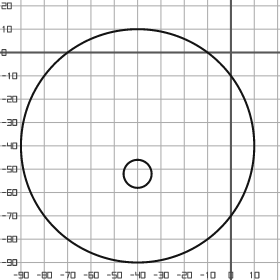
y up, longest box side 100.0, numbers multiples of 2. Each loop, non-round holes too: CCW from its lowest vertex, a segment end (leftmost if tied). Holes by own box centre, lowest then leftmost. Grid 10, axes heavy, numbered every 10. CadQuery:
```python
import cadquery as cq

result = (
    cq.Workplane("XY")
    .moveTo(-40.0, -40.0)
    .circle(50.0)
    .moveTo(-40.0, -52.0)
    .circle(6.0)
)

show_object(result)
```